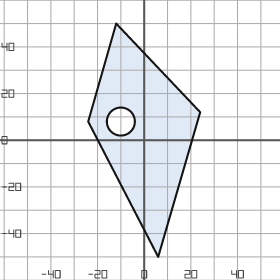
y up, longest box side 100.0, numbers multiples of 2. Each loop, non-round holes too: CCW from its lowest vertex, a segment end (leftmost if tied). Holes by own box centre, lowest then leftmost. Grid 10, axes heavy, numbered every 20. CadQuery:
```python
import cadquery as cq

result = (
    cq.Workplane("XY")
    .moveTo(6.0, -50.0)
    .lineTo(24.0, 12.0)
    .lineTo(-12.0, 50.0)
    .lineTo(-24.0, 8.0)
    .close()
    .moveTo(-10.0, 8.0)
    .circle(6.0)
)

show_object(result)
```